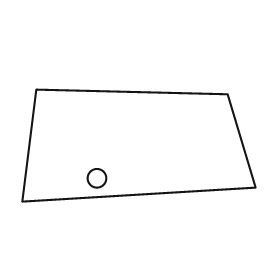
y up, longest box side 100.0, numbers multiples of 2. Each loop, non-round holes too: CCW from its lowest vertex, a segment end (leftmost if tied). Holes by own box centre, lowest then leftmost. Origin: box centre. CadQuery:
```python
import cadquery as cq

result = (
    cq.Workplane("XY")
    .moveTo(-50.0, -24.0)
    .lineTo(50.0, -18.0)
    .lineTo(38.0, 22.0)
    .lineTo(-44.0, 24.0)
    .close()
    .moveTo(-18.0, -14.0)
    .circle(4.0)
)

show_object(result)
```